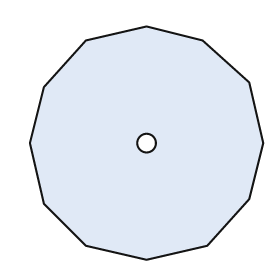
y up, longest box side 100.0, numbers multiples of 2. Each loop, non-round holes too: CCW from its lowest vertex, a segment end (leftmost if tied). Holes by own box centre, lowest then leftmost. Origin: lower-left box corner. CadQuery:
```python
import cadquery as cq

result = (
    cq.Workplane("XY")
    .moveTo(50.0, 0.0)
    .lineTo(76.0, 6.0)
    .lineTo(94.0, 26.0)
    .lineTo(100.0, 50.0)
    .lineTo(94.0, 76.0)
    .lineTo(74.0, 94.0)
    .lineTo(50.0, 100.0)
    .lineTo(24.0, 94.0)
    .lineTo(6.0, 74.0)
    .lineTo(0.0, 50.0)
    .lineTo(6.0, 24.0)
    .lineTo(24.0, 6.0)
    .close()
    .moveTo(50.0, 50.0)
    .circle(4.0)
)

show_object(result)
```